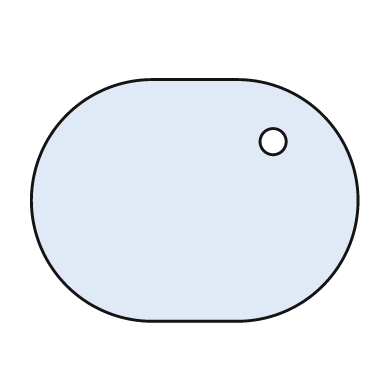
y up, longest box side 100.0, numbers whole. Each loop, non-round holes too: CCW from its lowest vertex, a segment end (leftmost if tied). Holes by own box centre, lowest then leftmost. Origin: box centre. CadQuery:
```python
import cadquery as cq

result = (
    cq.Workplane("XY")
    .moveTo(-13.0, -37.0)
    .lineTo(13.0, -37.0)
    .threePointArc((50.0, 0.0), (13.0, 37.0))
    .lineTo(-13.0, 37.0)
    .threePointArc((-50.0, 0.0), (-13.0, -37.0))
    .close()
    .moveTo(24.0, 18.0)
    .circle(4.0)
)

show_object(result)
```